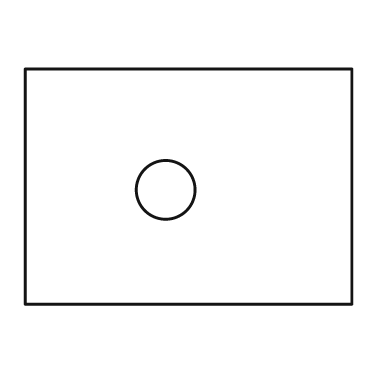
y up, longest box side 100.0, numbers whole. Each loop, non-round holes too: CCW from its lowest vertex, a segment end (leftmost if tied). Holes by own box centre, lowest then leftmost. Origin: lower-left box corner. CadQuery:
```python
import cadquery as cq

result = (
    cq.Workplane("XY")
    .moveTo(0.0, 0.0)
    .lineTo(100.0, 0.0)
    .lineTo(100.0, 72.0)
    .lineTo(0.0, 72.0)
    .close()
    .moveTo(43.0, 35.0)
    .circle(9.0)
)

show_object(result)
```